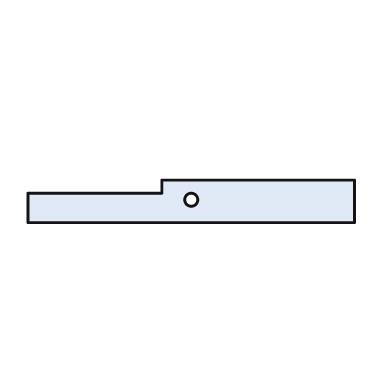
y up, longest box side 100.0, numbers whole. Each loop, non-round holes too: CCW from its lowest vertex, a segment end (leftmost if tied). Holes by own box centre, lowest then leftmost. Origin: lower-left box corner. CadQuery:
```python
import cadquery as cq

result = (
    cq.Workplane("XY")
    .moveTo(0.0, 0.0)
    .lineTo(100.0, 0.0)
    .lineTo(100.0, 13.0)
    .lineTo(41.0, 13.0)
    .lineTo(41.0, 9.0)
    .lineTo(0.0, 9.0)
    .close()
    .moveTo(50.0, 7.0)
    .circle(2.0)
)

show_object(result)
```